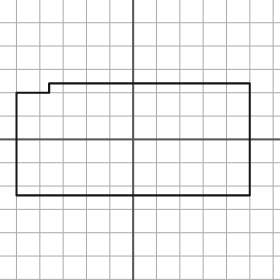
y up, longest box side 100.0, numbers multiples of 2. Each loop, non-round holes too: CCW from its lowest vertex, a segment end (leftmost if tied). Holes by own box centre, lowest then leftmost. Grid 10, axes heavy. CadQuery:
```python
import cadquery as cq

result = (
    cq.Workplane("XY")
    .moveTo(-50.0, -24.0)
    .lineTo(50.0, -24.0)
    .lineTo(50.0, 24.0)
    .lineTo(-36.0, 24.0)
    .lineTo(-36.0, 20.0)
    .lineTo(-50.0, 20.0)
    .close()
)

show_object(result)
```